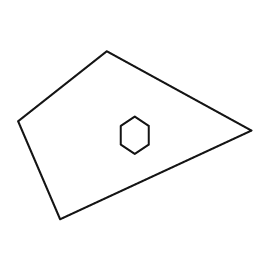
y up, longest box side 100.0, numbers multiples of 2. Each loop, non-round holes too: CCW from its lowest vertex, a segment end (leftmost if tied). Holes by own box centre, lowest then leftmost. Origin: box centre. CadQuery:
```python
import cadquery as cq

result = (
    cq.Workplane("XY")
    .moveTo(-32.0, -36.0)
    .lineTo(50.0, 2.0)
    .lineTo(-12.0, 36.0)
    .lineTo(-50.0, 6.0)
    .close()
    .moveTo(0.0, -8.0)
    .lineTo(6.0, -4.0)
    .lineTo(6.0, 4.0)
    .lineTo(0.0, 8.0)
    .lineTo(-6.0, 4.0)
    .lineTo(-6.0, -4.0)
    .close()
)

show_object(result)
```